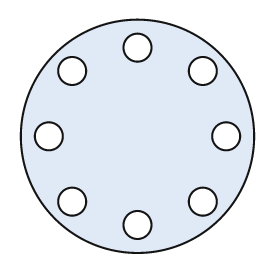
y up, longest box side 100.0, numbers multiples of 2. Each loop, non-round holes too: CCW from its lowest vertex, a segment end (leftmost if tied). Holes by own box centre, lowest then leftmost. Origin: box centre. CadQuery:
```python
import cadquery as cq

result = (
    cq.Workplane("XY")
    .moveTo(0.0, 0.0)
    .circle(50.0)
    .moveTo(0.0, -38.0)
    .circle(6.0)
    .moveTo(-28.0, -28.0)
    .circle(6.0)
    .moveTo(28.0, -28.0)
    .circle(6.0)
    .moveTo(-38.0, 0.0)
    .circle(6.0)
    .moveTo(38.0, 0.0)
    .circle(6.0)
    .moveTo(-28.0, 28.0)
    .circle(6.0)
    .moveTo(28.0, 28.0)
    .circle(6.0)
    .moveTo(0.0, 38.0)
    .circle(6.0)
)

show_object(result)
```